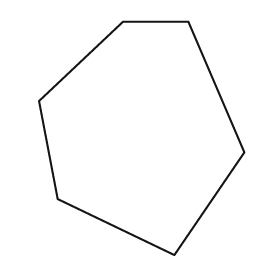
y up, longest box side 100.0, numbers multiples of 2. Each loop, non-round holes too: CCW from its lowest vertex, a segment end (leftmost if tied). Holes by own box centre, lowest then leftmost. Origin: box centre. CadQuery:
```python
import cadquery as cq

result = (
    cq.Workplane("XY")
    .moveTo(14.0, -50.0)
    .lineTo(44.0, -6.0)
    .lineTo(20.0, 50.0)
    .lineTo(-8.0, 50.0)
    .lineTo(-44.0, 16.0)
    .lineTo(-36.0, -26.0)
    .close()
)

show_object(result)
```